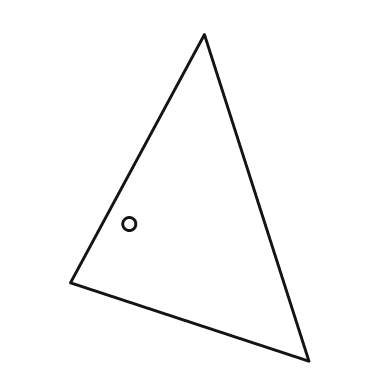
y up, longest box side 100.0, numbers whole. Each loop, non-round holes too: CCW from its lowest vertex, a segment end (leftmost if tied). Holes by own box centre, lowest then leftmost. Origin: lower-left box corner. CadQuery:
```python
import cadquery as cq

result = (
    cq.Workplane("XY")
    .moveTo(73.0, 0.0)
    .lineTo(41.0, 100.0)
    .lineTo(0.0, 24.0)
    .close()
    .moveTo(18.0, 42.0)
    .circle(2.0)
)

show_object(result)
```